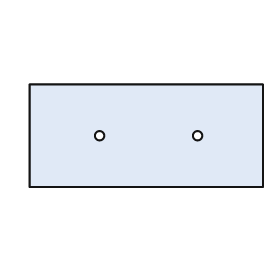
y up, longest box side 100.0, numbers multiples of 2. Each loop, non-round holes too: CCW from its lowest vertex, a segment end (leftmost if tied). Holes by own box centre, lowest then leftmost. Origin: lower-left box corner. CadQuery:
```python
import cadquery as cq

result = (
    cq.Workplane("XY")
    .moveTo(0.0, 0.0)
    .lineTo(100.0, 0.0)
    .lineTo(100.0, 44.0)
    .lineTo(0.0, 44.0)
    .close()
    .moveTo(30.0, 22.0)
    .circle(2.0)
    .moveTo(72.0, 22.0)
    .circle(2.0)
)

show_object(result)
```